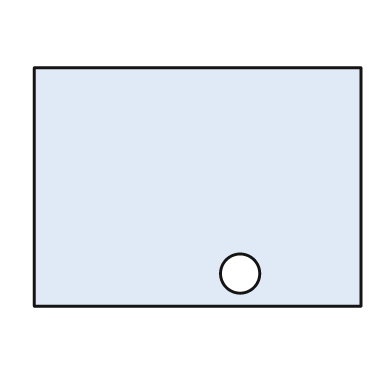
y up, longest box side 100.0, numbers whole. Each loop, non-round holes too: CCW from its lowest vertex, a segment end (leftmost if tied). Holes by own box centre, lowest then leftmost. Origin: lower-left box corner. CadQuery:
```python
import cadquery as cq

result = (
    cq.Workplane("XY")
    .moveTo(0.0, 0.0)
    .lineTo(100.0, 0.0)
    .lineTo(100.0, 73.0)
    .lineTo(0.0, 73.0)
    .close()
    .moveTo(63.0, 10.0)
    .circle(6.0)
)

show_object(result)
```